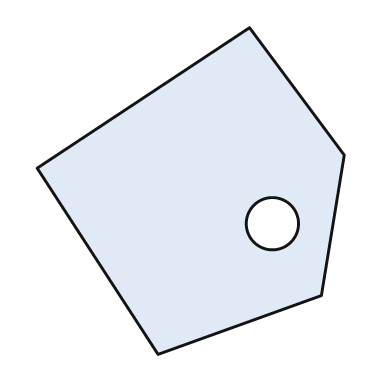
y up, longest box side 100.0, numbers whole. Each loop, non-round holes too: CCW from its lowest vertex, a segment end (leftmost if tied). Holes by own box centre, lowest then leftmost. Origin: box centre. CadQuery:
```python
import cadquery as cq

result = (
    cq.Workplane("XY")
    .moveTo(-10.0, -50.0)
    .lineTo(40.0, -32.0)
    .lineTo(47.0, 11.0)
    .lineTo(18.0, 50.0)
    .lineTo(-47.0, 7.0)
    .close()
    .moveTo(25.0, -10.0)
    .circle(8.0)
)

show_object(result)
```